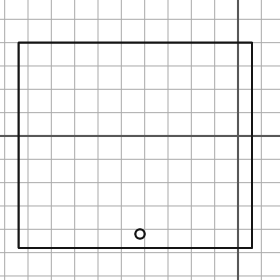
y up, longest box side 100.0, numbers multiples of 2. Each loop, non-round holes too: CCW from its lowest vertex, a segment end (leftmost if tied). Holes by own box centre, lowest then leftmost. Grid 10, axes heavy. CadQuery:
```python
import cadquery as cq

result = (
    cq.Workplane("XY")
    .moveTo(-94.0, -48.0)
    .lineTo(6.0, -48.0)
    .lineTo(6.0, 40.0)
    .lineTo(-94.0, 40.0)
    .close()
    .moveTo(-42.0, -42.0)
    .circle(2.0)
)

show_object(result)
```